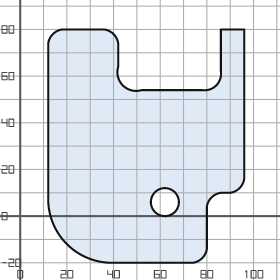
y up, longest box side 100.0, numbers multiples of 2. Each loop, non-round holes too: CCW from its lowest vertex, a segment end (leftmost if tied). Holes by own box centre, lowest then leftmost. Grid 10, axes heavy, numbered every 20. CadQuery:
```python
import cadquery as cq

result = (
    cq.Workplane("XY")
    .moveTo(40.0, -20.0)
    .lineTo(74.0, -20.0)
    .threePointArc((78.0, -18.0), (80.0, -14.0))
    .lineTo(80.0, 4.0)
    .threePointArc((82.0, 8.0), (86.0, 10.0))
    .lineTo(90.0, 10.0)
    .threePointArc((94.0, 12.0), (96.0, 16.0))
    .lineTo(96.0, 80.0)
    .lineTo(86.0, 80.0)
    .lineTo(86.0, 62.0)
    .threePointArc((84.0, 56.0), (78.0, 54.0))
    .lineTo(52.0, 54.0)
    .threePointArc((44.0, 56.0), (42.0, 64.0))
    .lineTo(42.0, 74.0)
    .threePointArc((40.0, 78.0), (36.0, 80.0))
    .lineTo(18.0, 80.0)
    .threePointArc((14.0, 78.0), (12.0, 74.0))
    .lineTo(12.0, 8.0)
    .threePointArc((20.0, -12.0), (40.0, -20.0))
    .close()
    .moveTo(62.0, 6.0)
    .circle(6.0)
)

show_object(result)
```